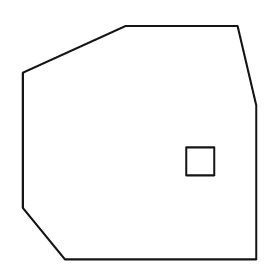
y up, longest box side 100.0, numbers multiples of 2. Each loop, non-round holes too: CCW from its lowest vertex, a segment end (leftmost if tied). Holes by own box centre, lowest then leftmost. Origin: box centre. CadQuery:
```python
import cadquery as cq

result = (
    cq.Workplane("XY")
    .moveTo(-32.0, -50.0)
    .lineTo(50.0, -50.0)
    .lineTo(50.0, 16.0)
    .lineTo(42.0, 50.0)
    .lineTo(-6.0, 50.0)
    .lineTo(-50.0, 30.0)
    .lineTo(-50.0, -28.0)
    .close()
    .moveTo(20.0, -14.0)
    .lineTo(32.0, -14.0)
    .lineTo(32.0, -2.0)
    .lineTo(20.0, -2.0)
    .close()
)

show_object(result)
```